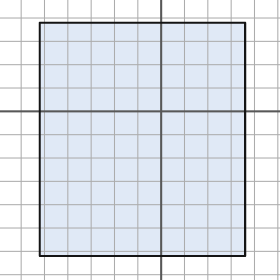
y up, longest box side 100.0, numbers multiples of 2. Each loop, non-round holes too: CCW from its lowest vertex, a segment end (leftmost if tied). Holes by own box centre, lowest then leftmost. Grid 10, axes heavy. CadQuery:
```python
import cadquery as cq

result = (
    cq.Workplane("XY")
    .moveTo(-52.0, -62.0)
    .lineTo(36.0, -62.0)
    .lineTo(36.0, 38.0)
    .lineTo(-52.0, 38.0)
    .close()
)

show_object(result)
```